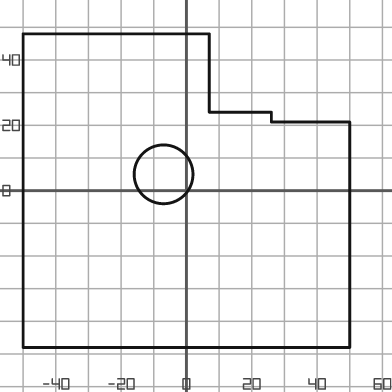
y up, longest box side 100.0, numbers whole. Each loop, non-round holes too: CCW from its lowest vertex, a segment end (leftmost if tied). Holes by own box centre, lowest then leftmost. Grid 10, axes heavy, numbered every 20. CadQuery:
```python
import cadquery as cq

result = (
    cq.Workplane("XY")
    .moveTo(-50.0, -48.0)
    .lineTo(50.0, -48.0)
    .lineTo(50.0, 21.0)
    .lineTo(26.0, 21.0)
    .lineTo(26.0, 24.0)
    .lineTo(7.0, 24.0)
    .lineTo(7.0, 48.0)
    .lineTo(-50.0, 48.0)
    .close()
    .moveTo(-7.0, 5.0)
    .circle(9.0)
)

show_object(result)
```